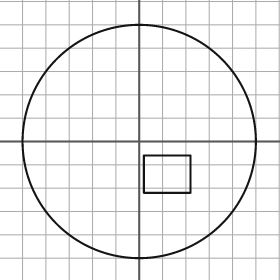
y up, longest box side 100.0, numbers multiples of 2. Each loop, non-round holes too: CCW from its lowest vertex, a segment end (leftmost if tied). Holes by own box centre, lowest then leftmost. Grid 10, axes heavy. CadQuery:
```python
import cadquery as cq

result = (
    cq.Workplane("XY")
    .moveTo(0.0, 0.0)
    .circle(50.0)
    .moveTo(2.0, -22.0)
    .lineTo(22.0, -22.0)
    .lineTo(22.0, -6.0)
    .lineTo(2.0, -6.0)
    .close()
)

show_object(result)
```